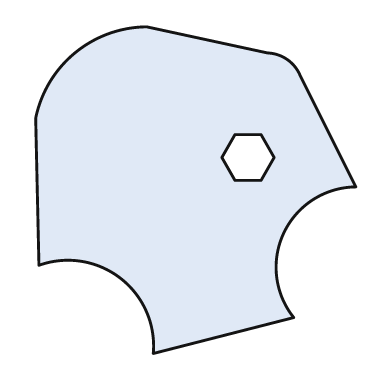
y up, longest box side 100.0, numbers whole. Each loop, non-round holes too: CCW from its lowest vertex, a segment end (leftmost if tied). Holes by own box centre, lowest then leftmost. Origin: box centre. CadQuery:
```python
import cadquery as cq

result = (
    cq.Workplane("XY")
    .moveTo(-13.0, -50.0)
    .lineTo(30.0, -39.0)
    .threePointArc((27.0, -13.0), (49.0, 1.0))
    .lineTo(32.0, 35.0)
    .threePointArc((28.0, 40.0), (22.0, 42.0))
    .lineTo(-15.0, 50.0)
    .threePointArc((-37.0, 42.0), (-49.0, 22.0))
    .lineTo(-48.0, -23.0)
    .threePointArc((-23.0, -27.0), (-13.0, -50.0))
    .close()
    .moveTo(12.0, 3.0)
    .lineTo(20.0, 3.0)
    .lineTo(24.0, 10.0)
    .lineTo(20.0, 17.0)
    .lineTo(12.0, 17.0)
    .lineTo(8.0, 10.0)
    .close()
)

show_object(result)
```